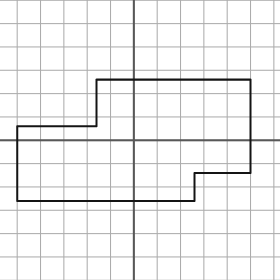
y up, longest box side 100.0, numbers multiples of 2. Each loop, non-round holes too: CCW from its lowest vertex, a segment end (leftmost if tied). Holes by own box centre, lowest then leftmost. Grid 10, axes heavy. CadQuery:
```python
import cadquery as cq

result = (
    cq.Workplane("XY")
    .moveTo(-50.0, -26.0)
    .lineTo(26.0, -26.0)
    .lineTo(26.0, -14.0)
    .lineTo(50.0, -14.0)
    .lineTo(50.0, 26.0)
    .lineTo(-16.0, 26.0)
    .lineTo(-16.0, 6.0)
    .lineTo(-50.0, 6.0)
    .close()
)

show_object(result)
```